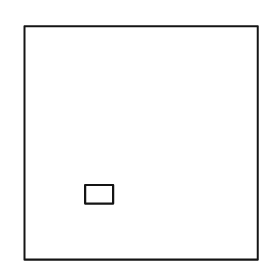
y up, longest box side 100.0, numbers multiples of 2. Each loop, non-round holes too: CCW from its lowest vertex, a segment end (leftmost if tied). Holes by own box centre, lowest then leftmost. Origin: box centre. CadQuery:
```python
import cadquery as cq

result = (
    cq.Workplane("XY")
    .moveTo(-50.0, -50.0)
    .lineTo(50.0, -50.0)
    .lineTo(50.0, 50.0)
    .lineTo(-50.0, 50.0)
    .close()
    .moveTo(-24.0, -26.0)
    .lineTo(-12.0, -26.0)
    .lineTo(-12.0, -18.0)
    .lineTo(-24.0, -18.0)
    .close()
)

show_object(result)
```